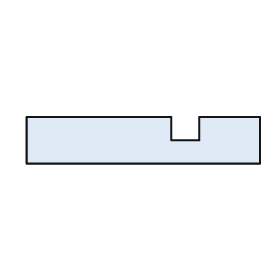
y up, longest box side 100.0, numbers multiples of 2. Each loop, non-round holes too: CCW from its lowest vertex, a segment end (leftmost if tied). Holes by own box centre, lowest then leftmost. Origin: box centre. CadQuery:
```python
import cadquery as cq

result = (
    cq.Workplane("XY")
    .moveTo(-50.0, -10.0)
    .lineTo(50.0, -10.0)
    .lineTo(50.0, 10.0)
    .lineTo(24.0, 10.0)
    .lineTo(24.0, 0.0)
    .lineTo(12.0, 0.0)
    .lineTo(12.0, 10.0)
    .lineTo(-50.0, 10.0)
    .close()
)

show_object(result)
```